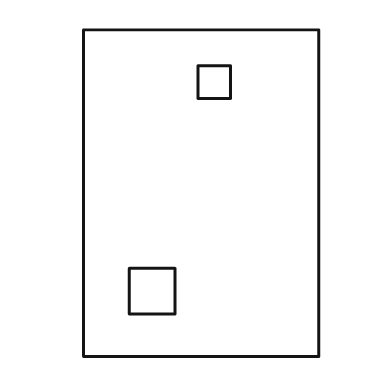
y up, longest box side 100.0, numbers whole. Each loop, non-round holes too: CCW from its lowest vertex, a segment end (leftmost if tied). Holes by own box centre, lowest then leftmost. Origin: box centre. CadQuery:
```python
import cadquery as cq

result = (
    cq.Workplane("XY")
    .moveTo(-36.0, -50.0)
    .lineTo(36.0, -50.0)
    .lineTo(36.0, 50.0)
    .lineTo(-36.0, 50.0)
    .close()
    .moveTo(-22.0, -37.0)
    .lineTo(-8.0, -37.0)
    .lineTo(-8.0, -23.0)
    .lineTo(-22.0, -23.0)
    .close()
    .moveTo(-1.0, 29.0)
    .lineTo(9.0, 29.0)
    .lineTo(9.0, 39.0)
    .lineTo(-1.0, 39.0)
    .close()
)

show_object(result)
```